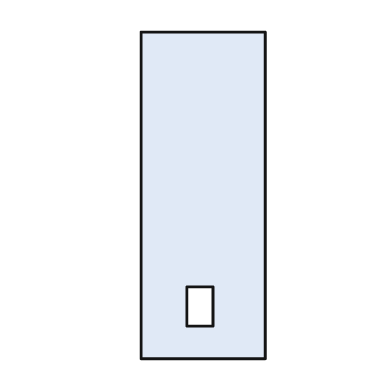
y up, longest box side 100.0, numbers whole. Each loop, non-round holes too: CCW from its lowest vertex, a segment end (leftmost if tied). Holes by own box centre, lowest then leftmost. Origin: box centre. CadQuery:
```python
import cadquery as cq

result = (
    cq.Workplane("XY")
    .moveTo(-19.0, -50.0)
    .lineTo(19.0, -50.0)
    .lineTo(19.0, 50.0)
    .lineTo(-19.0, 50.0)
    .close()
    .moveTo(-5.0, -40.0)
    .lineTo(3.0, -40.0)
    .lineTo(3.0, -28.0)
    .lineTo(-5.0, -28.0)
    .close()
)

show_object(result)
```